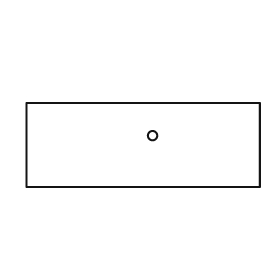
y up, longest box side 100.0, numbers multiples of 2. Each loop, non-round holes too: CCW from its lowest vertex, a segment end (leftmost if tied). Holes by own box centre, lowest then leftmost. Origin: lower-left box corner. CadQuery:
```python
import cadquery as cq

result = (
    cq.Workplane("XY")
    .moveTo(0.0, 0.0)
    .lineTo(100.0, 0.0)
    .lineTo(100.0, 36.0)
    .lineTo(0.0, 36.0)
    .close()
    .moveTo(54.0, 22.0)
    .circle(2.0)
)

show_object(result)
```